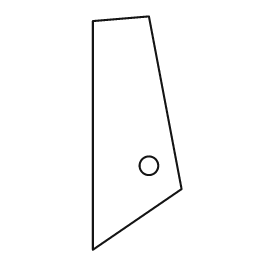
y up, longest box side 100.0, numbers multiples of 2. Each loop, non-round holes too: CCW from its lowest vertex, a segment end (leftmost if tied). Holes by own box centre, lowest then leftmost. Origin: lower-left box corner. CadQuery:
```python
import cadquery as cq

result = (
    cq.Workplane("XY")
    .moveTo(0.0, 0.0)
    .lineTo(38.0, 26.0)
    .lineTo(24.0, 100.0)
    .lineTo(0.0, 98.0)
    .close()
    .moveTo(24.0, 36.0)
    .circle(4.0)
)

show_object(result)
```